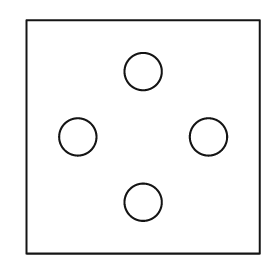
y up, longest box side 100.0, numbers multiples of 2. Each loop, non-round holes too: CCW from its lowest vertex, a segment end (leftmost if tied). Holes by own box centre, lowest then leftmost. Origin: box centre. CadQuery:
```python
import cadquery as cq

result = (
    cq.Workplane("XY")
    .moveTo(-50.0, -50.0)
    .lineTo(50.0, -50.0)
    .lineTo(50.0, 50.0)
    .lineTo(-50.0, 50.0)
    .close()
    .moveTo(0.0, -28.0)
    .circle(8.0)
    .moveTo(-28.0, 0.0)
    .circle(8.0)
    .moveTo(28.0, 0.0)
    .circle(8.0)
    .moveTo(0.0, 28.0)
    .circle(8.0)
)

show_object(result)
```